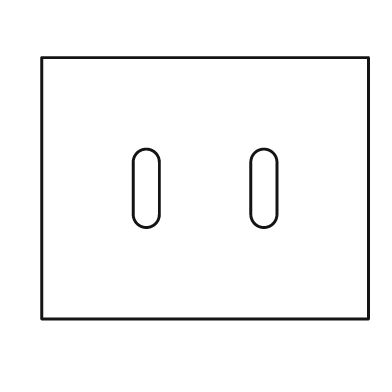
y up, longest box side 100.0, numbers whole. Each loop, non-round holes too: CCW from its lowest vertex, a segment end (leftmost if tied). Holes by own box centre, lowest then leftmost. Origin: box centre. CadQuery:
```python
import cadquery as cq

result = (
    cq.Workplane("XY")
    .moveTo(-50.0, -40.0)
    .lineTo(50.0, -40.0)
    .lineTo(50.0, 40.0)
    .lineTo(-50.0, 40.0)
    .close()
    .moveTo(-22.0, -8.0)
    .threePointArc((-18.0, -12.0), (-14.0, -8.0))
    .lineTo(-14.0, 8.0)
    .threePointArc((-18.0, 12.0), (-22.0, 8.0))
    .close()
    .moveTo(14.0, -8.0)
    .threePointArc((18.0, -12.0), (22.0, -8.0))
    .lineTo(22.0, 8.0)
    .threePointArc((18.0, 12.0), (14.0, 8.0))
    .close()
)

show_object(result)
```